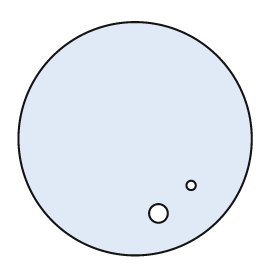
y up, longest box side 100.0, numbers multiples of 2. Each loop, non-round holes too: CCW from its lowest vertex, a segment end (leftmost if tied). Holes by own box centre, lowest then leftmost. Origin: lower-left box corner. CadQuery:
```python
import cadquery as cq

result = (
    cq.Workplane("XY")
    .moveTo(50.0, 50.0)
    .circle(50.0)
    .moveTo(60.0, 18.0)
    .circle(4.0)
    .moveTo(74.0, 30.0)
    .circle(2.0)
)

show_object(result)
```